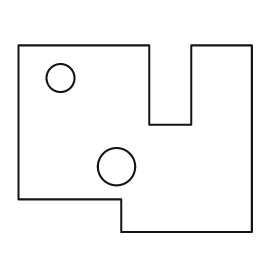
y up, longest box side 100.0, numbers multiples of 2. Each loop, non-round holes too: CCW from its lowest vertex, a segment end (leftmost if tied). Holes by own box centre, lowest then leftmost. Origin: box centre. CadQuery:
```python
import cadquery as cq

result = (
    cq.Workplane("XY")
    .moveTo(-6.0, -40.0)
    .lineTo(50.0, -40.0)
    .lineTo(50.0, 40.0)
    .lineTo(24.0, 40.0)
    .lineTo(24.0, 6.0)
    .lineTo(6.0, 6.0)
    .lineTo(6.0, 40.0)
    .lineTo(-50.0, 40.0)
    .lineTo(-50.0, -26.0)
    .lineTo(-6.0, -26.0)
    .close()
    .moveTo(-8.0, -12.0)
    .circle(8.0)
    .moveTo(-32.0, 26.0)
    .circle(6.0)
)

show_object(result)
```